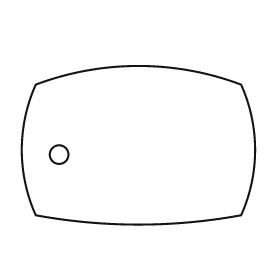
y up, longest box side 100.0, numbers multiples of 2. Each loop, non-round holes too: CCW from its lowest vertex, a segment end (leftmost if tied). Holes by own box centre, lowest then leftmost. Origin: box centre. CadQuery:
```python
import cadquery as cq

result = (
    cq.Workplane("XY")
    .moveTo(-44.0, -30.0)
    .threePointArc((0.0, -34.0), (44.0, -30.0))
    .threePointArc((50.0, -2.0), (44.0, 26.0))
    .threePointArc((0.0, 34.0), (-44.0, 26.0))
    .threePointArc((-50.0, -2.0), (-44.0, -30.0))
    .close()
    .moveTo(-34.0, -4.0)
    .circle(4.0)
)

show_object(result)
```